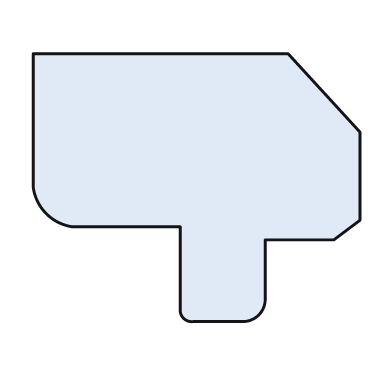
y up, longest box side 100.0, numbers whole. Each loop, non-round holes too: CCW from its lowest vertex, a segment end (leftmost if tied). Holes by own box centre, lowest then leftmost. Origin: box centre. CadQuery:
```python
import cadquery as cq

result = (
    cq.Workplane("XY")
    .moveTo(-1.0, -41.0)
    .lineTo(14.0, -41.0)
    .threePointArc((19.0, -39.0), (21.0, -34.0))
    .lineTo(21.0, -16.0)
    .lineTo(42.0, -16.0)
    .lineTo(50.0, -10.0)
    .lineTo(50.0, 17.0)
    .lineTo(28.0, 41.0)
    .lineTo(-50.0, 41.0)
    .lineTo(-50.0, 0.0)
    .threePointArc((-46.0, -8.0), (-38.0, -12.0))
    .lineTo(-5.0, -12.0)
    .lineTo(-5.0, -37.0)
    .threePointArc((-4.0, -40.0), (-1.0, -41.0))
    .close()
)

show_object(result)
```